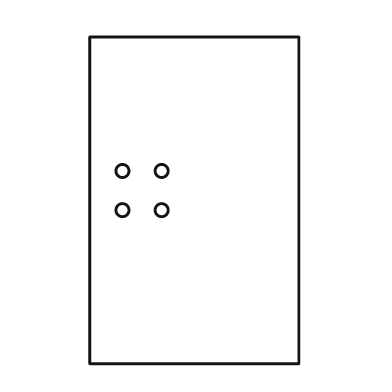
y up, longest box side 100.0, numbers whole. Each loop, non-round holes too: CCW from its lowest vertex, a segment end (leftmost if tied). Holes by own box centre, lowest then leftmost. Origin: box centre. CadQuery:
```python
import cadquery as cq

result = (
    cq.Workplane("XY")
    .moveTo(-32.0, -50.0)
    .lineTo(32.0, -50.0)
    .lineTo(32.0, 50.0)
    .lineTo(-32.0, 50.0)
    .close()
    .moveTo(-22.0, -3.0)
    .circle(2.0)
    .moveTo(-10.0, -3.0)
    .circle(2.0)
    .moveTo(-22.0, 9.0)
    .circle(2.0)
    .moveTo(-10.0, 9.0)
    .circle(2.0)
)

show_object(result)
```